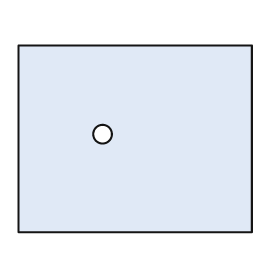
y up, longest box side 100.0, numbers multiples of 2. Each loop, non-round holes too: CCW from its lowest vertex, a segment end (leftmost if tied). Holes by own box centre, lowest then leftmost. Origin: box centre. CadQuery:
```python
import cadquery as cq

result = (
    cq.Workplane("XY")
    .moveTo(-50.0, -40.0)
    .lineTo(50.0, -40.0)
    .lineTo(50.0, 40.0)
    .lineTo(-50.0, 40.0)
    .close()
    .moveTo(-14.0, 2.0)
    .circle(4.0)
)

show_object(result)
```